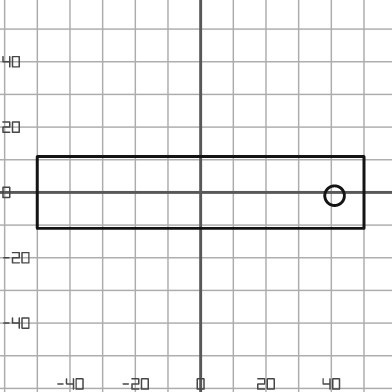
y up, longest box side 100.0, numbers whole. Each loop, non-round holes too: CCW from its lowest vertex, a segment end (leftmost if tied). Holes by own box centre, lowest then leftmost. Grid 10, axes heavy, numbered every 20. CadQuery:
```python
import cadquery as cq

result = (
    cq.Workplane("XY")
    .moveTo(-50.0, -11.0)
    .lineTo(50.0, -11.0)
    .lineTo(50.0, 11.0)
    .lineTo(-50.0, 11.0)
    .close()
    .moveTo(41.0, -1.0)
    .circle(3.0)
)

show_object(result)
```